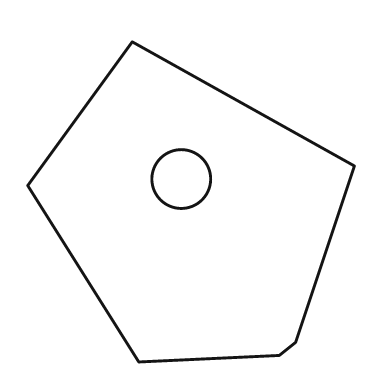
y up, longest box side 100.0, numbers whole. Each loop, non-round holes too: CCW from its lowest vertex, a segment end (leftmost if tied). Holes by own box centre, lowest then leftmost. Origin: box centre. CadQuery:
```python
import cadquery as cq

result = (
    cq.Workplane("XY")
    .moveTo(-16.0, -49.0)
    .lineTo(27.0, -47.0)
    .lineTo(32.0, -43.0)
    .lineTo(50.0, 11.0)
    .lineTo(-18.0, 49.0)
    .lineTo(-50.0, 5.0)
    .close()
    .moveTo(-3.0, 7.0)
    .circle(9.0)
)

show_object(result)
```